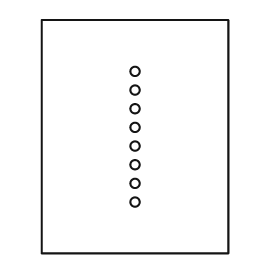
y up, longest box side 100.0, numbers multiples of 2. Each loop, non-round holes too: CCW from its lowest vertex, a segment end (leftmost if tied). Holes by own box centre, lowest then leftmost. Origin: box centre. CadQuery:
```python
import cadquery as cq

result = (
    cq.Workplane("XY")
    .moveTo(-40.0, -50.0)
    .lineTo(40.0, -50.0)
    .lineTo(40.0, 50.0)
    .lineTo(-40.0, 50.0)
    .close()
    .moveTo(0.0, -28.0)
    .circle(2.0)
    .moveTo(0.0, -20.0)
    .circle(2.0)
    .moveTo(0.0, -12.0)
    .circle(2.0)
    .moveTo(0.0, -4.0)
    .circle(2.0)
    .moveTo(0.0, 4.0)
    .circle(2.0)
    .moveTo(0.0, 12.0)
    .circle(2.0)
    .moveTo(0.0, 20.0)
    .circle(2.0)
    .moveTo(0.0, 28.0)
    .circle(2.0)
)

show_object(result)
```